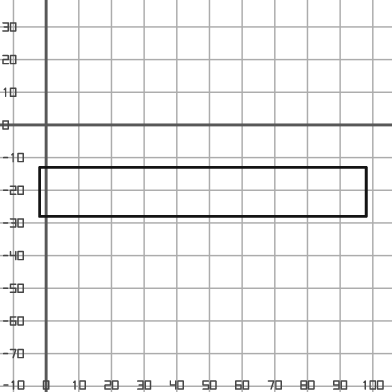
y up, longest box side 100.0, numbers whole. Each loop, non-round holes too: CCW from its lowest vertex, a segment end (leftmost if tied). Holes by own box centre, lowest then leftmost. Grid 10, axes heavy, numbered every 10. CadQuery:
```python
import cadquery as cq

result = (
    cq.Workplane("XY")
    .moveTo(-2.0, -28.0)
    .lineTo(98.0, -28.0)
    .lineTo(98.0, -13.0)
    .lineTo(-2.0, -13.0)
    .close()
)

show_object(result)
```